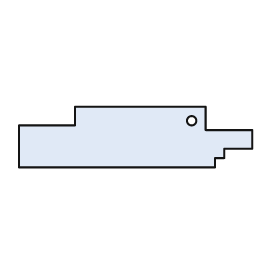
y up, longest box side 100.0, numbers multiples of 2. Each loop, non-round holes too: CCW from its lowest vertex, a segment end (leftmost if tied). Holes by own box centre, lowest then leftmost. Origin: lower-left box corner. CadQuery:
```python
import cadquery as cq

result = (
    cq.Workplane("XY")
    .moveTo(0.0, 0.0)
    .lineTo(84.0, 0.0)
    .lineTo(84.0, 4.0)
    .lineTo(88.0, 4.0)
    .lineTo(88.0, 8.0)
    .lineTo(100.0, 8.0)
    .lineTo(100.0, 16.0)
    .lineTo(80.0, 16.0)
    .lineTo(80.0, 26.0)
    .lineTo(24.0, 26.0)
    .lineTo(24.0, 18.0)
    .lineTo(0.0, 18.0)
    .close()
    .moveTo(74.0, 20.0)
    .circle(2.0)
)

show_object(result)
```